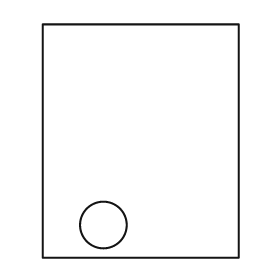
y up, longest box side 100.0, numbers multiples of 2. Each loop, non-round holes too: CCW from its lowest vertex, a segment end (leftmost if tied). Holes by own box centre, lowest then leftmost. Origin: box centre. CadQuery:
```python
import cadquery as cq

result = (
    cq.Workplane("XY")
    .moveTo(-42.0, -50.0)
    .lineTo(42.0, -50.0)
    .lineTo(42.0, 50.0)
    .lineTo(-42.0, 50.0)
    .close()
    .moveTo(-16.0, -36.0)
    .circle(10.0)
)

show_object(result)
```